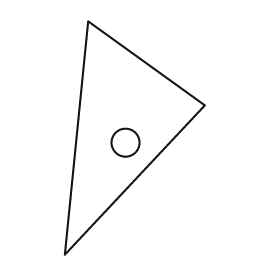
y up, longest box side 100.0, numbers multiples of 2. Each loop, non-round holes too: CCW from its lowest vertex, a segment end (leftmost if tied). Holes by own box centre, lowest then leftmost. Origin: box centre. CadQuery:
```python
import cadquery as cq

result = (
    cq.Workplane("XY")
    .moveTo(-30.0, -50.0)
    .lineTo(30.0, 14.0)
    .lineTo(-20.0, 50.0)
    .close()
    .moveTo(-4.0, -2.0)
    .circle(6.0)
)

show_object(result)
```